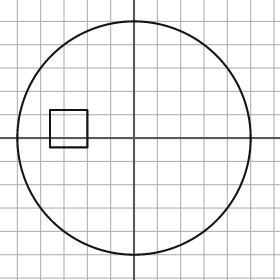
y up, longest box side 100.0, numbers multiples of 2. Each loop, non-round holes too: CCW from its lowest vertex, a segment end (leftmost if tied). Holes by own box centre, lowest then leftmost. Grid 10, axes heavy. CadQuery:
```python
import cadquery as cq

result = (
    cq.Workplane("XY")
    .moveTo(0.0, 0.0)
    .circle(50.0)
    .moveTo(-36.0, -4.0)
    .lineTo(-20.0, -4.0)
    .lineTo(-20.0, 12.0)
    .lineTo(-36.0, 12.0)
    .close()
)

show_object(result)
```